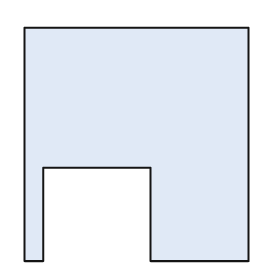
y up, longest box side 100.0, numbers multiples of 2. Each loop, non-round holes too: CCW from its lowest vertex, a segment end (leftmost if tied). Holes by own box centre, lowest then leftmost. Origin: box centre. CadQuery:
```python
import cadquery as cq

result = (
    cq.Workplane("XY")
    .moveTo(-48.0, -50.0)
    .lineTo(-40.0, -50.0)
    .lineTo(-40.0, -10.0)
    .lineTo(6.0, -10.0)
    .lineTo(6.0, -50.0)
    .lineTo(48.0, -50.0)
    .lineTo(48.0, 50.0)
    .lineTo(-48.0, 50.0)
    .close()
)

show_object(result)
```